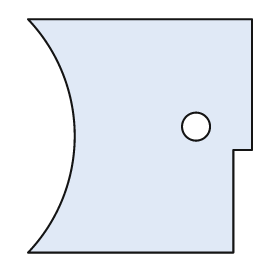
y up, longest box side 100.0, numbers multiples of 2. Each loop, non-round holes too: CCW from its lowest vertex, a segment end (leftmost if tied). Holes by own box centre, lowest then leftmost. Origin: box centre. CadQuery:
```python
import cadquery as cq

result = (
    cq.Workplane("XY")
    .moveTo(-48.0, -50.0)
    .lineTo(40.0, -50.0)
    .lineTo(40.0, -6.0)
    .lineTo(48.0, -6.0)
    .lineTo(48.0, 50.0)
    .lineTo(-48.0, 50.0)
    .threePointArc((-28.0, 0.0), (-48.0, -50.0))
    .close()
    .moveTo(24.0, 4.0)
    .circle(6.0)
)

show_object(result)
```